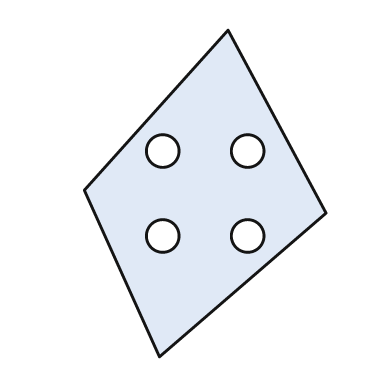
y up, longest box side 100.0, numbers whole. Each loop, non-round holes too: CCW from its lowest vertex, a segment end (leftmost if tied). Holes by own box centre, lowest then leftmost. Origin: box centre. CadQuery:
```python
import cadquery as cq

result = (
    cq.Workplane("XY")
    .moveTo(-14.0, -50.0)
    .lineTo(37.0, -6.0)
    .lineTo(7.0, 50.0)
    .lineTo(-37.0, 1.0)
    .close()
    .moveTo(-13.0, -13.0)
    .circle(5.0)
    .moveTo(13.0, -13.0)
    .circle(5.0)
    .moveTo(-13.0, 13.0)
    .circle(5.0)
    .moveTo(13.0, 13.0)
    .circle(5.0)
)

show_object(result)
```